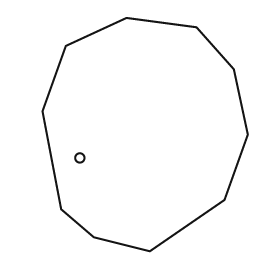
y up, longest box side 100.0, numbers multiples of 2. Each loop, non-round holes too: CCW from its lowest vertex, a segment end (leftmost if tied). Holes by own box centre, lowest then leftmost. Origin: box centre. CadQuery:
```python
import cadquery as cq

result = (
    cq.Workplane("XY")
    .moveTo(2.0, -50.0)
    .lineTo(34.0, -28.0)
    .lineTo(44.0, 0.0)
    .lineTo(38.0, 28.0)
    .lineTo(22.0, 46.0)
    .lineTo(-8.0, 50.0)
    .lineTo(-34.0, 38.0)
    .lineTo(-44.0, 10.0)
    .lineTo(-36.0, -32.0)
    .lineTo(-22.0, -44.0)
    .close()
    .moveTo(-28.0, -10.0)
    .circle(2.0)
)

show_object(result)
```